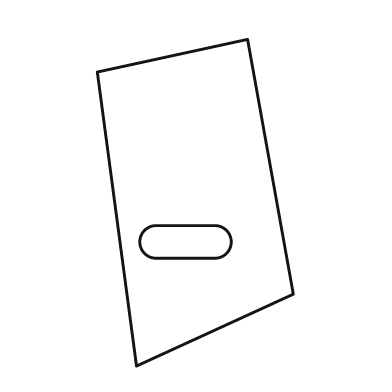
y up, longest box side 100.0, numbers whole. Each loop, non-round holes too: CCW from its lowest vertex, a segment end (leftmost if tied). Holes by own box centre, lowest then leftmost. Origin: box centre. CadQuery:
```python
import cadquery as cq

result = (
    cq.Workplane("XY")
    .moveTo(-18.0, -50.0)
    .lineTo(30.0, -28.0)
    .lineTo(16.0, 50.0)
    .lineTo(-30.0, 40.0)
    .close()
    .moveTo(-12.0, -17.0)
    .lineTo(6.0, -17.0)
    .threePointArc((11.0, -12.0), (6.0, -7.0))
    .lineTo(-12.0, -7.0)
    .threePointArc((-17.0, -12.0), (-12.0, -17.0))
    .close()
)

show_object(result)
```